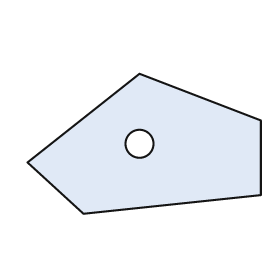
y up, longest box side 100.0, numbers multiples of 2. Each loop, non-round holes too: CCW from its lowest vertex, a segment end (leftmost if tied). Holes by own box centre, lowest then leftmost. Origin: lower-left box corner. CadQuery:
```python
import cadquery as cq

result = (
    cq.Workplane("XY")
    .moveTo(24.0, 0.0)
    .lineTo(100.0, 8.0)
    .lineTo(100.0, 40.0)
    .lineTo(48.0, 60.0)
    .lineTo(0.0, 22.0)
    .close()
    .moveTo(48.0, 30.0)
    .circle(6.0)
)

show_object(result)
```